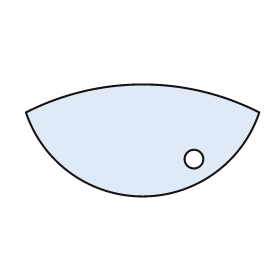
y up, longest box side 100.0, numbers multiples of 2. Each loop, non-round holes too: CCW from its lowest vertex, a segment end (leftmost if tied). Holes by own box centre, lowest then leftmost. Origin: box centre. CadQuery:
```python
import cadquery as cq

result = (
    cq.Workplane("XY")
    .moveTo(-50.0, 12.0)
    .threePointArc((0.0, -24.0), (50.0, 12.0))
    .threePointArc((0.0, 24.0), (-50.0, 12.0))
    .close()
    .moveTo(22.0, -8.0)
    .circle(4.0)
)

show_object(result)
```